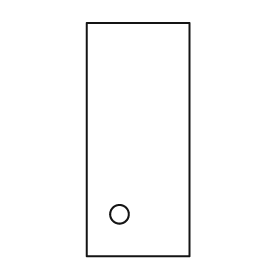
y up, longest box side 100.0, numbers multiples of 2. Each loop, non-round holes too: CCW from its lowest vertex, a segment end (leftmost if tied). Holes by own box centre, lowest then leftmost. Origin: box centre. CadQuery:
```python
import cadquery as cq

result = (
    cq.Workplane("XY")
    .moveTo(-22.0, -50.0)
    .lineTo(22.0, -50.0)
    .lineTo(22.0, 50.0)
    .lineTo(-22.0, 50.0)
    .close()
    .moveTo(-8.0, -32.0)
    .circle(4.0)
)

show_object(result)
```